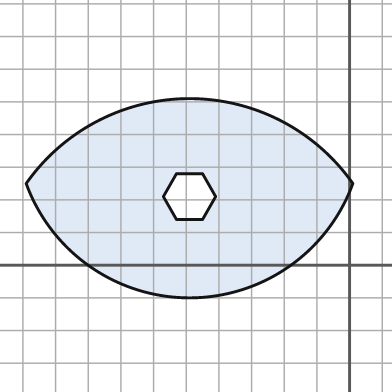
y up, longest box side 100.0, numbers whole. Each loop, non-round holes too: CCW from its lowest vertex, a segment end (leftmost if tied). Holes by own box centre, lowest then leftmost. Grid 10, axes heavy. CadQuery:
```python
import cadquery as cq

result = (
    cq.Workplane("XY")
    .moveTo(-99.0, 25.0)
    .threePointArc((-49.0, -10.0), (1.0, 25.0))
    .threePointArc((-49.0, 51.0), (-99.0, 25.0))
    .close()
    .moveTo(-53.0, 14.0)
    .lineTo(-45.0, 14.0)
    .lineTo(-41.0, 21.0)
    .lineTo(-45.0, 28.0)
    .lineTo(-53.0, 28.0)
    .lineTo(-57.0, 21.0)
    .close()
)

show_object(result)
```